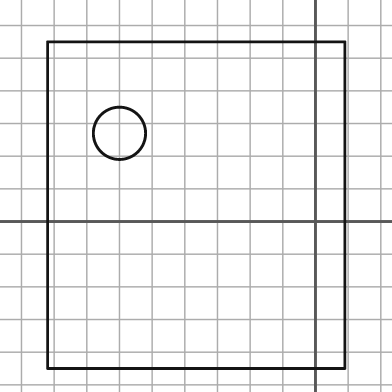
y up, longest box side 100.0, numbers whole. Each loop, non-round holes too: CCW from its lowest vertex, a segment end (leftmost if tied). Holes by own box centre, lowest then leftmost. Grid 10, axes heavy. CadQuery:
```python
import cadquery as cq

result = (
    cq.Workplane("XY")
    .moveTo(-82.0, -45.0)
    .lineTo(9.0, -45.0)
    .lineTo(9.0, 55.0)
    .lineTo(-82.0, 55.0)
    .close()
    .moveTo(-60.0, 27.0)
    .circle(8.0)
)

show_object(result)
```